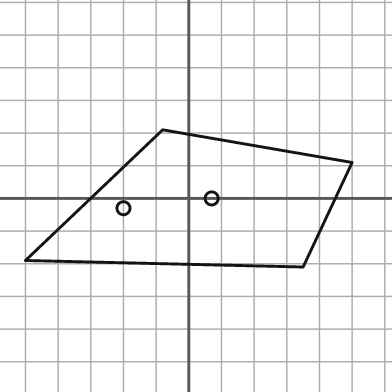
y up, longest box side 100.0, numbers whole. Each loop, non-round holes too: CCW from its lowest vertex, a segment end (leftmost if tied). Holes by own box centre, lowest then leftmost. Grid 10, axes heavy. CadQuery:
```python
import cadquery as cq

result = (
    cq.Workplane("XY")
    .moveTo(35.0, -21.0)
    .lineTo(50.0, 11.0)
    .lineTo(-8.0, 21.0)
    .lineTo(-50.0, -19.0)
    .close()
    .moveTo(-20.0, -3.0)
    .circle(2.0)
    .moveTo(7.0, 0.0)
    .circle(2.0)
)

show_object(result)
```